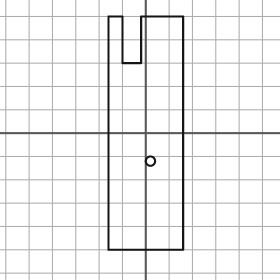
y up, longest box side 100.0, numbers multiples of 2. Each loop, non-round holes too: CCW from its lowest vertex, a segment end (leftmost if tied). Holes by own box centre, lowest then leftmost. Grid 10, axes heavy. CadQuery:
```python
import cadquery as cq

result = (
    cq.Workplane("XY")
    .moveTo(-16.0, -50.0)
    .lineTo(16.0, -50.0)
    .lineTo(16.0, 50.0)
    .lineTo(-2.0, 50.0)
    .lineTo(-2.0, 30.0)
    .lineTo(-10.0, 30.0)
    .lineTo(-10.0, 50.0)
    .lineTo(-16.0, 50.0)
    .close()
    .moveTo(2.0, -12.0)
    .circle(2.0)
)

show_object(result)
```